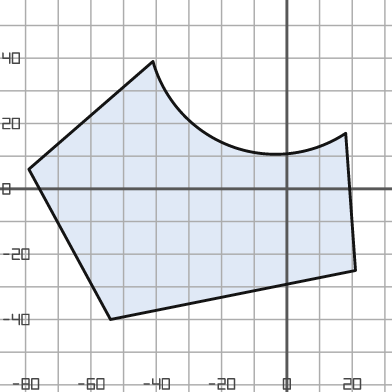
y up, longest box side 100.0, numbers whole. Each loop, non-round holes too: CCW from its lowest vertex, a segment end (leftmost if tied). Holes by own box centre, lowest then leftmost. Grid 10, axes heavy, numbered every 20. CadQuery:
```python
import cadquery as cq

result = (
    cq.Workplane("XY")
    .moveTo(-54.0, -40.0)
    .lineTo(21.0, -25.0)
    .lineTo(18.0, 17.0)
    .threePointArc((-17.0, 13.0), (-41.0, 39.0))
    .lineTo(-79.0, 6.0)
    .close()
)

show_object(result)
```